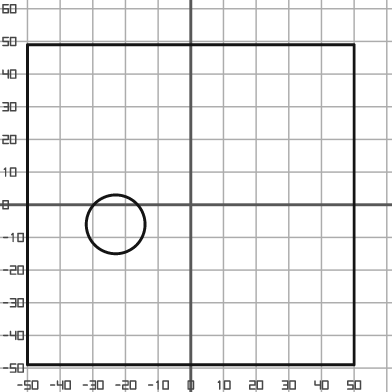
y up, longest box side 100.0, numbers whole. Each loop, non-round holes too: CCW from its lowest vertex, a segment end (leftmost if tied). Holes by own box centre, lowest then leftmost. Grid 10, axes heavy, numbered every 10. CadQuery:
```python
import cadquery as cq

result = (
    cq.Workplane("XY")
    .moveTo(-50.0, -49.0)
    .lineTo(50.0, -49.0)
    .lineTo(50.0, 49.0)
    .lineTo(-50.0, 49.0)
    .close()
    .moveTo(-23.0, -6.0)
    .circle(9.0)
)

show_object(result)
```